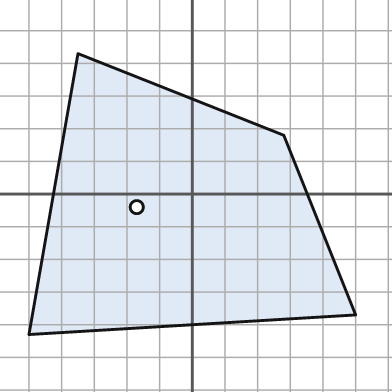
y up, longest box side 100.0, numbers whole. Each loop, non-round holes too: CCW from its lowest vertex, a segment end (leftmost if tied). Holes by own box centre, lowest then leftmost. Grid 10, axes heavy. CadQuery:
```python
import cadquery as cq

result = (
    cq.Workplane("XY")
    .moveTo(-50.0, -43.0)
    .lineTo(50.0, -37.0)
    .lineTo(28.0, 18.0)
    .lineTo(-35.0, 43.0)
    .close()
    .moveTo(-17.0, -4.0)
    .circle(2.0)
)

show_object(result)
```